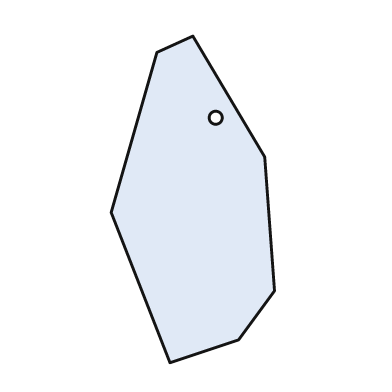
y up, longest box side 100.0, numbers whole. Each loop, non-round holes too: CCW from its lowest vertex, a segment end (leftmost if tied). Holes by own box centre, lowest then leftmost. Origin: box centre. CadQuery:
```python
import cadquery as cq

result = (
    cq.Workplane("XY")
    .moveTo(-7.0, -50.0)
    .lineTo(14.0, -43.0)
    .lineTo(25.0, -28.0)
    .lineTo(22.0, 13.0)
    .lineTo(0.0, 50.0)
    .lineTo(-11.0, 45.0)
    .lineTo(-25.0, -4.0)
    .close()
    .moveTo(7.0, 25.0)
    .circle(2.0)
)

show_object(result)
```